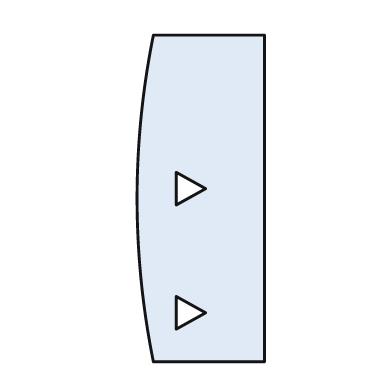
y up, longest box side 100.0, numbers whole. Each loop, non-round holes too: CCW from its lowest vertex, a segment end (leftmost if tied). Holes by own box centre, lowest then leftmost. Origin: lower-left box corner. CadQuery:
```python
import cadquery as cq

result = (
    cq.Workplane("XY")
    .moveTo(5.0, 0.0)
    .lineTo(39.0, 0.0)
    .lineTo(39.0, 100.0)
    .lineTo(5.0, 100.0)
    .threePointArc((0.0, 50.0), (5.0, 0.0))
    .close()
    .moveTo(12.0, 10.0)
    .lineTo(21.0, 15.0)
    .lineTo(12.0, 20.0)
    .close()
    .moveTo(12.0, 48.0)
    .lineTo(21.0, 53.0)
    .lineTo(12.0, 58.0)
    .close()
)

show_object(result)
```